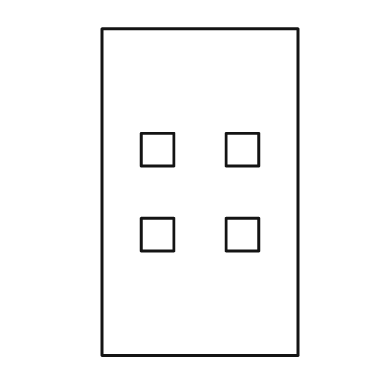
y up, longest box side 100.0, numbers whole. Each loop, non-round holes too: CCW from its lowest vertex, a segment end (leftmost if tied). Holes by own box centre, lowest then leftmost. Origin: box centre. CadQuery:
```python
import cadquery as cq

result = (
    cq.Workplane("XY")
    .moveTo(-30.0, -50.0)
    .lineTo(30.0, -50.0)
    .lineTo(30.0, 50.0)
    .lineTo(-30.0, 50.0)
    .close()
    .moveTo(-18.0, -18.0)
    .lineTo(-8.0, -18.0)
    .lineTo(-8.0, -8.0)
    .lineTo(-18.0, -8.0)
    .close()
    .moveTo(8.0, -18.0)
    .lineTo(18.0, -18.0)
    .lineTo(18.0, -8.0)
    .lineTo(8.0, -8.0)
    .close()
    .moveTo(-18.0, 8.0)
    .lineTo(-8.0, 8.0)
    .lineTo(-8.0, 18.0)
    .lineTo(-18.0, 18.0)
    .close()
    .moveTo(8.0, 8.0)
    .lineTo(18.0, 8.0)
    .lineTo(18.0, 18.0)
    .lineTo(8.0, 18.0)
    .close()
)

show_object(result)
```